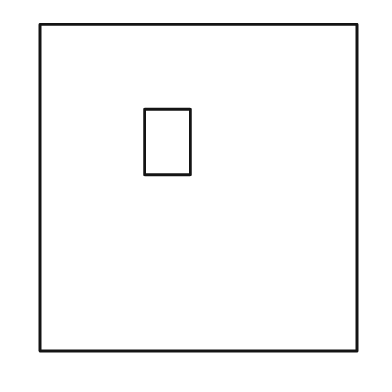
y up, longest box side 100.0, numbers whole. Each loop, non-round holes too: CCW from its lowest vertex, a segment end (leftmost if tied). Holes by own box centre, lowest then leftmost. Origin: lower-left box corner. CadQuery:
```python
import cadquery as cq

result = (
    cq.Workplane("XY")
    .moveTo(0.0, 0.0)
    .lineTo(97.0, 0.0)
    .lineTo(97.0, 100.0)
    .lineTo(0.0, 100.0)
    .close()
    .moveTo(32.0, 54.0)
    .lineTo(46.0, 54.0)
    .lineTo(46.0, 74.0)
    .lineTo(32.0, 74.0)
    .close()
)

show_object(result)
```